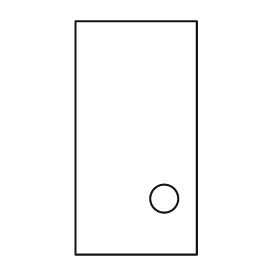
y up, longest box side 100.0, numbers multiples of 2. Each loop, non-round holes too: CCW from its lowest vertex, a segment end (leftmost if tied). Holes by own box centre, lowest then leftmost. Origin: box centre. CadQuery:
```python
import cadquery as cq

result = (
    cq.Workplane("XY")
    .moveTo(-26.0, -50.0)
    .lineTo(26.0, -50.0)
    .lineTo(26.0, 50.0)
    .lineTo(-26.0, 50.0)
    .close()
    .moveTo(12.0, -26.0)
    .circle(6.0)
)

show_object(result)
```